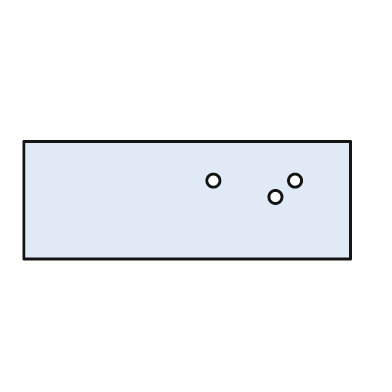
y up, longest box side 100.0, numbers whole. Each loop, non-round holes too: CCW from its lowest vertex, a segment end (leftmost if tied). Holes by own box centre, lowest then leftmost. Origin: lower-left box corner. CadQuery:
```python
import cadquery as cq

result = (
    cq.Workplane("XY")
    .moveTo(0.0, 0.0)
    .lineTo(100.0, 0.0)
    .lineTo(100.0, 36.0)
    .lineTo(0.0, 36.0)
    .close()
    .moveTo(77.0, 19.0)
    .circle(2.0)
    .moveTo(58.0, 24.0)
    .circle(2.0)
    .moveTo(83.0, 24.0)
    .circle(2.0)
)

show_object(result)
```